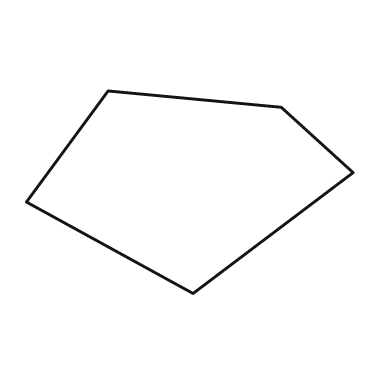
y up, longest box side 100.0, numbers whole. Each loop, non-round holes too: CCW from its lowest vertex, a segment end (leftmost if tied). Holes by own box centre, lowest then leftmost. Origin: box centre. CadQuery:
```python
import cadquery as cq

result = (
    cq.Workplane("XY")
    .moveTo(1.0, -31.0)
    .lineTo(50.0, 6.0)
    .lineTo(28.0, 26.0)
    .lineTo(-25.0, 31.0)
    .lineTo(-50.0, -3.0)
    .close()
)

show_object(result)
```